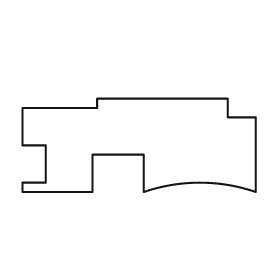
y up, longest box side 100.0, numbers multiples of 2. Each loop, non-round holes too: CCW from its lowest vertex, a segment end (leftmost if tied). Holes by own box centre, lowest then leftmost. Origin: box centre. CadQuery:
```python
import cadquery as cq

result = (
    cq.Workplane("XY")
    .moveTo(-50.0, -20.0)
    .lineTo(-20.0, -20.0)
    .lineTo(-20.0, -4.0)
    .lineTo(2.0, -4.0)
    .lineTo(2.0, -20.0)
    .threePointArc((26.0, -16.0), (50.0, -20.0))
    .lineTo(50.0, 12.0)
    .lineTo(38.0, 12.0)
    .lineTo(38.0, 20.0)
    .lineTo(-18.0, 20.0)
    .lineTo(-18.0, 16.0)
    .lineTo(-50.0, 16.0)
    .lineTo(-50.0, 0.0)
    .lineTo(-40.0, 0.0)
    .lineTo(-40.0, -16.0)
    .lineTo(-50.0, -16.0)
    .close()
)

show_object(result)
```